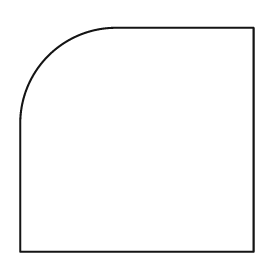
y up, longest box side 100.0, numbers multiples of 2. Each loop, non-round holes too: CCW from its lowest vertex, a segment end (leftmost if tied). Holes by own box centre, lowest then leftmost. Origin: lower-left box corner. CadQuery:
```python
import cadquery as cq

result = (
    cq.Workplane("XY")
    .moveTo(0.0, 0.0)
    .lineTo(100.0, 0.0)
    .lineTo(100.0, 96.0)
    .lineTo(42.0, 96.0)
    .threePointArc((12.0, 84.0), (0.0, 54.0))
    .close()
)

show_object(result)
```